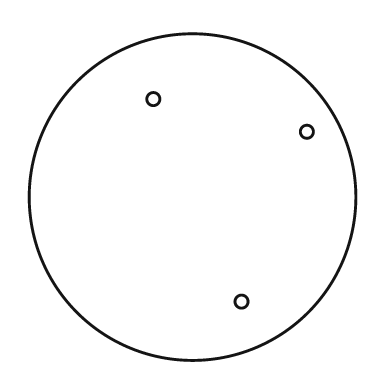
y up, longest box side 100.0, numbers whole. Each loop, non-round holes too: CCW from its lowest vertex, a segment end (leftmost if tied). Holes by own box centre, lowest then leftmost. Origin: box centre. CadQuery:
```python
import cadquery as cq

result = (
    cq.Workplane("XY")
    .moveTo(0.0, 0.0)
    .circle(50.0)
    .moveTo(15.0, -32.0)
    .circle(2.0)
    .moveTo(35.0, 20.0)
    .circle(2.0)
    .moveTo(-12.0, 30.0)
    .circle(2.0)
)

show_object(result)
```